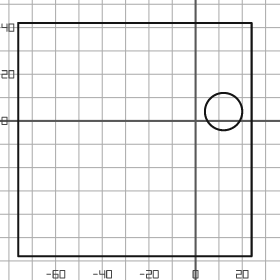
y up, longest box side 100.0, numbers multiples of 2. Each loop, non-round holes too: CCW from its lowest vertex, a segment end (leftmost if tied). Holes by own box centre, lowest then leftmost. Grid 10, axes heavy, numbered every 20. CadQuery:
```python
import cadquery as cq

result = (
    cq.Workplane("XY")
    .moveTo(-76.0, -58.0)
    .lineTo(24.0, -58.0)
    .lineTo(24.0, 42.0)
    .lineTo(-76.0, 42.0)
    .close()
    .moveTo(12.0, 4.0)
    .circle(8.0)
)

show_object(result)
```